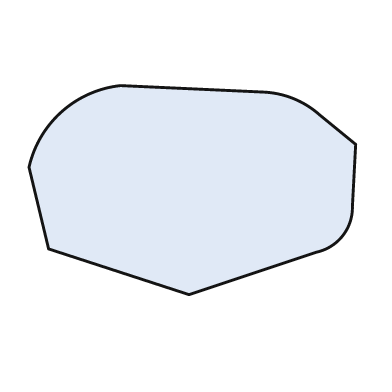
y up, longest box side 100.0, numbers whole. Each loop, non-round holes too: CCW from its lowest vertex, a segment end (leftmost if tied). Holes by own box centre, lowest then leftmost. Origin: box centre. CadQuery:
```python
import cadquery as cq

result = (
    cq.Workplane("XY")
    .moveTo(-1.0, -32.0)
    .lineTo(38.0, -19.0)
    .threePointArc((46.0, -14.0), (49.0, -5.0))
    .lineTo(50.0, 14.0)
    .lineTo(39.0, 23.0)
    .threePointArc((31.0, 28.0), (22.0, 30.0))
    .lineTo(-22.0, 32.0)
    .threePointArc((-40.0, 24.0), (-50.0, 7.0))
    .lineTo(-44.0, -18.0)
    .close()
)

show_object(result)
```